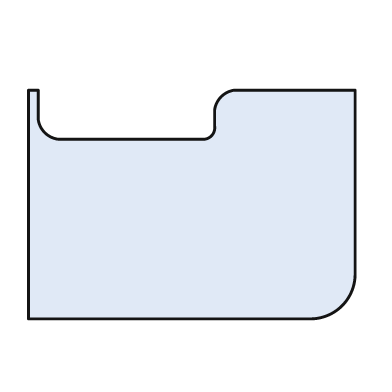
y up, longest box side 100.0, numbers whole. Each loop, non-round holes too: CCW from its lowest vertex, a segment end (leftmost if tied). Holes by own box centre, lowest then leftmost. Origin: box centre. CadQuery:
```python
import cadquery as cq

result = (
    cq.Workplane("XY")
    .moveTo(-50.0, -35.0)
    .lineTo(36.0, -35.0)
    .threePointArc((46.0, -31.0), (50.0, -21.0))
    .lineTo(50.0, 35.0)
    .lineTo(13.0, 35.0)
    .threePointArc((9.0, 33.0), (7.0, 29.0))
    .lineTo(7.0, 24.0)
    .threePointArc((6.0, 21.0), (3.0, 20.0))
    .lineTo(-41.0, 20.0)
    .threePointArc((-45.0, 22.0), (-47.0, 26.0))
    .lineTo(-47.0, 35.0)
    .lineTo(-50.0, 35.0)
    .close()
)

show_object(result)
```